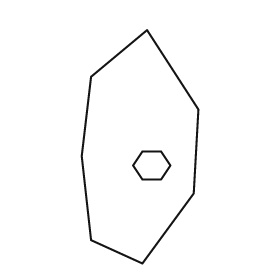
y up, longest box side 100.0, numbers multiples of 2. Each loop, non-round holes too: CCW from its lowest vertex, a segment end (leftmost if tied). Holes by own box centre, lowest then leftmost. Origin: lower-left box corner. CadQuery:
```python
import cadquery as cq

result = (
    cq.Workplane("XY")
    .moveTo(26.0, 0.0)
    .lineTo(48.0, 30.0)
    .lineTo(50.0, 66.0)
    .lineTo(28.0, 100.0)
    .lineTo(4.0, 80.0)
    .lineTo(0.0, 46.0)
    .lineTo(4.0, 10.0)
    .close()
    .moveTo(26.0, 36.0)
    .lineTo(34.0, 36.0)
    .lineTo(38.0, 42.0)
    .lineTo(34.0, 48.0)
    .lineTo(26.0, 48.0)
    .lineTo(22.0, 42.0)
    .close()
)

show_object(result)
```